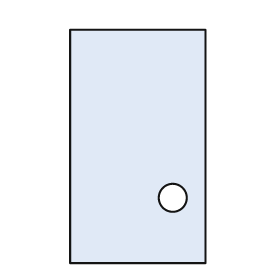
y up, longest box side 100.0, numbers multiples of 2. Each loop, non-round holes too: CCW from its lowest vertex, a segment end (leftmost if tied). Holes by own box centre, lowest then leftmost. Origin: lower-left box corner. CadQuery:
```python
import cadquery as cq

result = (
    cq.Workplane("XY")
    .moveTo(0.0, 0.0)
    .lineTo(58.0, 0.0)
    .lineTo(58.0, 100.0)
    .lineTo(0.0, 100.0)
    .close()
    .moveTo(44.0, 28.0)
    .circle(6.0)
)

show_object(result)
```